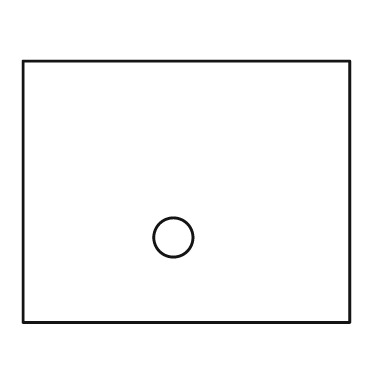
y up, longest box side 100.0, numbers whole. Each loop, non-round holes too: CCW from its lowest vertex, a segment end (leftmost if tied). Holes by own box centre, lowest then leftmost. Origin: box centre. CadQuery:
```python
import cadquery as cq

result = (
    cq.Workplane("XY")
    .moveTo(-50.0, -40.0)
    .lineTo(50.0, -40.0)
    .lineTo(50.0, 40.0)
    .lineTo(-50.0, 40.0)
    .close()
    .moveTo(-4.0, -14.0)
    .circle(6.0)
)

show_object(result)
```